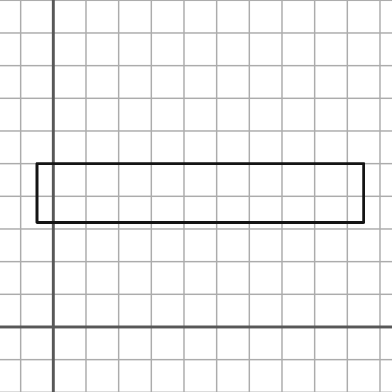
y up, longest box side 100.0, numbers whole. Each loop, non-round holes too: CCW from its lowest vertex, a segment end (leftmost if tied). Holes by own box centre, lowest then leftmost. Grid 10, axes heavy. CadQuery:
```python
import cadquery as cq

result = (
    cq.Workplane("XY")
    .moveTo(-5.0, 32.0)
    .lineTo(95.0, 32.0)
    .lineTo(95.0, 50.0)
    .lineTo(-5.0, 50.0)
    .close()
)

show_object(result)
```